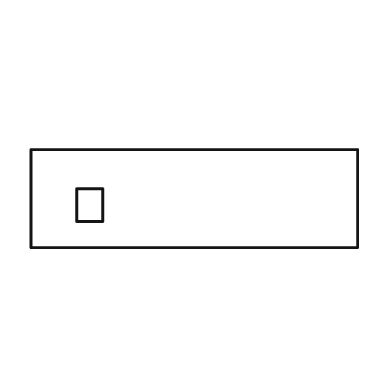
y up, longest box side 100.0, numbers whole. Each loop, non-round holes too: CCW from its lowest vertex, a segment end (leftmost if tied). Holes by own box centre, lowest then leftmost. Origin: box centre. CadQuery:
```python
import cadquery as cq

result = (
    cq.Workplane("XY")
    .moveTo(-50.0, -15.0)
    .lineTo(50.0, -15.0)
    .lineTo(50.0, 15.0)
    .lineTo(-50.0, 15.0)
    .close()
    .moveTo(-36.0, -7.0)
    .lineTo(-28.0, -7.0)
    .lineTo(-28.0, 3.0)
    .lineTo(-36.0, 3.0)
    .close()
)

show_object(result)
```